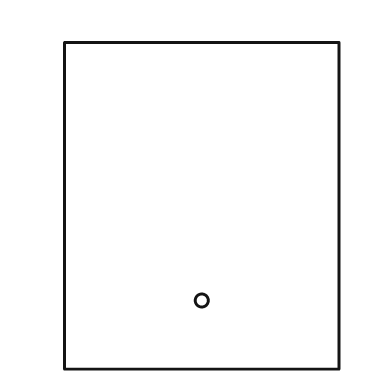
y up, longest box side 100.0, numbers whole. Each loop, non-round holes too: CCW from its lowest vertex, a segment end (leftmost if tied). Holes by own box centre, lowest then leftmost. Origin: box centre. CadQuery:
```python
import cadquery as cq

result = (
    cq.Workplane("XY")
    .moveTo(-42.0, -50.0)
    .lineTo(42.0, -50.0)
    .lineTo(42.0, 50.0)
    .lineTo(-42.0, 50.0)
    .close()
    .moveTo(0.0, -29.0)
    .circle(2.0)
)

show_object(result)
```